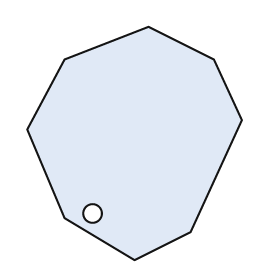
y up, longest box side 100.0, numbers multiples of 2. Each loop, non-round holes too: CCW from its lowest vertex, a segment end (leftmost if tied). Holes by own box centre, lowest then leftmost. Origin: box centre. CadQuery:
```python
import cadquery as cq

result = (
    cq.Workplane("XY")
    .moveTo(0.0, -50.0)
    .lineTo(24.0, -38.0)
    .lineTo(46.0, 10.0)
    .lineTo(34.0, 36.0)
    .lineTo(6.0, 50.0)
    .lineTo(-30.0, 36.0)
    .lineTo(-46.0, 6.0)
    .lineTo(-30.0, -32.0)
    .close()
    .moveTo(-18.0, -30.0)
    .circle(4.0)
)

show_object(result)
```